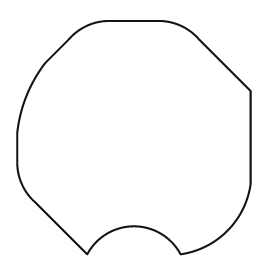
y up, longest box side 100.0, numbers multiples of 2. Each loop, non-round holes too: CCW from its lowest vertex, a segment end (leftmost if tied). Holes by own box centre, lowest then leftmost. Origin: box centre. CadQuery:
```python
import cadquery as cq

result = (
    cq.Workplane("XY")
    .moveTo(-20.0, -50.0)
    .threePointArc((0.0, -38.0), (20.0, -50.0))
    .threePointArc((40.0, -40.0), (50.0, -20.0))
    .lineTo(50.0, 20.0)
    .lineTo(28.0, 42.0)
    .threePointArc((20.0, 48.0), (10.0, 50.0))
    .lineTo(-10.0, 50.0)
    .threePointArc((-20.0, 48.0), (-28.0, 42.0))
    .lineTo(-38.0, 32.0)
    .threePointArc((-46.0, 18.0), (-50.0, 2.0))
    .lineTo(-50.0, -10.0)
    .threePointArc((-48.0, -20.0), (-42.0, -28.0))
    .close()
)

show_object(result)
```